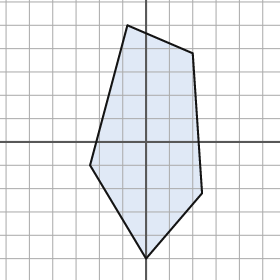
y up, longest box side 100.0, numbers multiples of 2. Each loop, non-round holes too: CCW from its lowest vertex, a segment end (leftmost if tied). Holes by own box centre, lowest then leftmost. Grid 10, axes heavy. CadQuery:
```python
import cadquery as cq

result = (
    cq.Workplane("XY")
    .moveTo(0.0, -50.0)
    .lineTo(24.0, -22.0)
    .lineTo(20.0, 38.0)
    .lineTo(-8.0, 50.0)
    .lineTo(-24.0, -10.0)
    .close()
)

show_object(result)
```